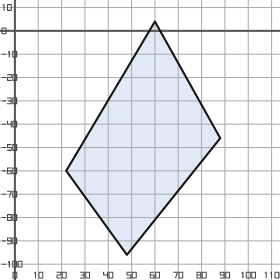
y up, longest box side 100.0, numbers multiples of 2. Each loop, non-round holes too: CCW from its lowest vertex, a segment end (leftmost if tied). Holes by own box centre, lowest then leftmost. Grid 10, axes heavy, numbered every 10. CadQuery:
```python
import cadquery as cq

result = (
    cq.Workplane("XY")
    .moveTo(48.0, -96.0)
    .lineTo(88.0, -46.0)
    .lineTo(60.0, 4.0)
    .lineTo(22.0, -60.0)
    .close()
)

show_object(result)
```